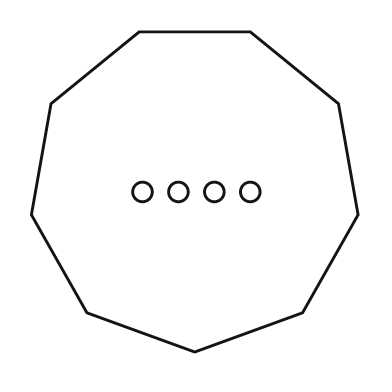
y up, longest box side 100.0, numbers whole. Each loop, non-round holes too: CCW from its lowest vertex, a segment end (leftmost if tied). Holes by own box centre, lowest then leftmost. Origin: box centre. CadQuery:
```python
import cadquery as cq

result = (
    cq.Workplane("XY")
    .moveTo(0.0, -49.0)
    .lineTo(33.0, -37.0)
    .lineTo(50.0, -7.0)
    .lineTo(44.0, 27.0)
    .lineTo(17.0, 49.0)
    .lineTo(-17.0, 49.0)
    .lineTo(-44.0, 27.0)
    .lineTo(-50.0, -7.0)
    .lineTo(-33.0, -37.0)
    .close()
    .moveTo(-16.0, 0.0)
    .circle(3.0)
    .moveTo(-5.0, 0.0)
    .circle(3.0)
    .moveTo(6.0, 0.0)
    .circle(3.0)
    .moveTo(17.0, 0.0)
    .circle(3.0)
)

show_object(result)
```